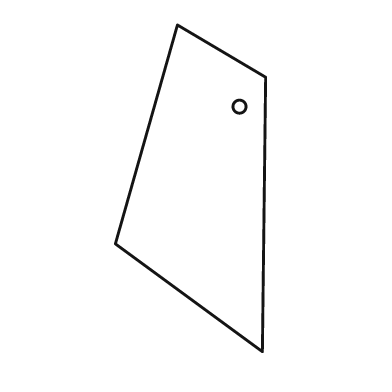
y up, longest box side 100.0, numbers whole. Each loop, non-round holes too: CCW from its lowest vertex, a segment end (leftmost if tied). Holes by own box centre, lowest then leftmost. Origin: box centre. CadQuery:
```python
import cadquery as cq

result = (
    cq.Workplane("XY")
    .moveTo(22.0, -50.0)
    .lineTo(23.0, 34.0)
    .lineTo(-4.0, 50.0)
    .lineTo(-23.0, -17.0)
    .close()
    .moveTo(15.0, 25.0)
    .circle(2.0)
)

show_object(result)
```